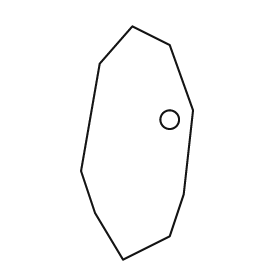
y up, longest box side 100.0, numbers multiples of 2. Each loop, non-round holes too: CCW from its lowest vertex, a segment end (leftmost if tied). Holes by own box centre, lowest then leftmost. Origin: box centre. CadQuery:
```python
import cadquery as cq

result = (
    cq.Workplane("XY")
    .moveTo(-6.0, -50.0)
    .lineTo(14.0, -40.0)
    .lineTo(20.0, -22.0)
    .lineTo(24.0, 14.0)
    .lineTo(14.0, 42.0)
    .lineTo(-2.0, 50.0)
    .lineTo(-16.0, 34.0)
    .lineTo(-24.0, -12.0)
    .lineTo(-18.0, -30.0)
    .close()
    .moveTo(14.0, 10.0)
    .circle(4.0)
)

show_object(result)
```